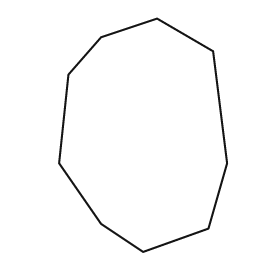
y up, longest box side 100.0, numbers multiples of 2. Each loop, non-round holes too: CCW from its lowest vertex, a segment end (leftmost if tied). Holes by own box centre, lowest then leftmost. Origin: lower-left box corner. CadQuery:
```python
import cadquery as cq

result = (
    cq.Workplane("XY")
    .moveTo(36.0, 0.0)
    .lineTo(64.0, 10.0)
    .lineTo(72.0, 38.0)
    .lineTo(66.0, 86.0)
    .lineTo(42.0, 100.0)
    .lineTo(18.0, 92.0)
    .lineTo(4.0, 76.0)
    .lineTo(0.0, 38.0)
    .lineTo(18.0, 12.0)
    .close()
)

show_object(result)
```